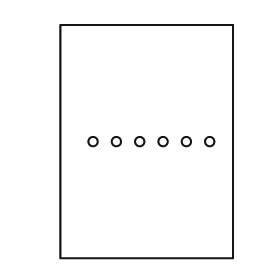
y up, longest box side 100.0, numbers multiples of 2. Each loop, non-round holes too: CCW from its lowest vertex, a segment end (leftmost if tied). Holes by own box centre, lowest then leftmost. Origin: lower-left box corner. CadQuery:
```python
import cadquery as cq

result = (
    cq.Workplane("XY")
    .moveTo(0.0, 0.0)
    .lineTo(74.0, 0.0)
    .lineTo(74.0, 100.0)
    .lineTo(0.0, 100.0)
    .close()
    .moveTo(14.0, 50.0)
    .circle(2.0)
    .moveTo(24.0, 50.0)
    .circle(2.0)
    .moveTo(34.0, 50.0)
    .circle(2.0)
    .moveTo(44.0, 50.0)
    .circle(2.0)
    .moveTo(54.0, 50.0)
    .circle(2.0)
    .moveTo(64.0, 50.0)
    .circle(2.0)
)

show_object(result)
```